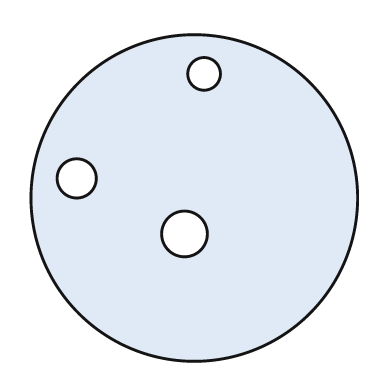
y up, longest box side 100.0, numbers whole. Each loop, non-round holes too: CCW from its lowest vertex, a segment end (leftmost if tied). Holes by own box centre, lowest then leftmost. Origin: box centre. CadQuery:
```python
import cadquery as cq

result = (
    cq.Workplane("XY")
    .moveTo(0.0, 0.0)
    .circle(50.0)
    .moveTo(-3.0, -11.0)
    .circle(7.0)
    .moveTo(-36.0, 6.0)
    .circle(6.0)
    .moveTo(3.0, 38.0)
    .circle(5.0)
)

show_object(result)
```